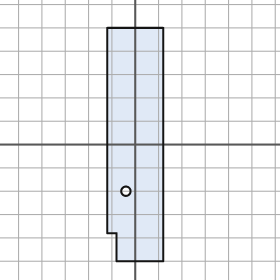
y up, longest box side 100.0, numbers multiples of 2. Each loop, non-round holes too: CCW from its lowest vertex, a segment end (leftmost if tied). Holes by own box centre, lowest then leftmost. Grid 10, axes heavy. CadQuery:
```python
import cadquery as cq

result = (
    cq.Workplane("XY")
    .moveTo(-8.0, -50.0)
    .lineTo(12.0, -50.0)
    .lineTo(12.0, 50.0)
    .lineTo(-12.0, 50.0)
    .lineTo(-12.0, -38.0)
    .lineTo(-8.0, -38.0)
    .close()
    .moveTo(-4.0, -20.0)
    .circle(2.0)
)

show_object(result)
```